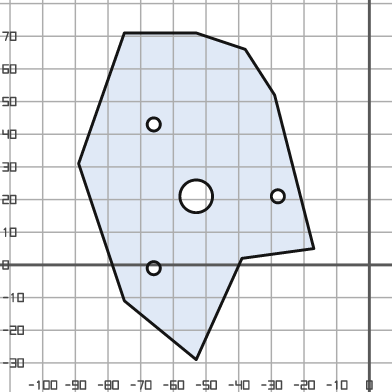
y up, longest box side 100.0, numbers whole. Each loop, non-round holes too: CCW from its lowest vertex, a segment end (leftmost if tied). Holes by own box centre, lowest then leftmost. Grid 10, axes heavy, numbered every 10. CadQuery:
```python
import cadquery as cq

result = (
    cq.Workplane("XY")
    .moveTo(-53.0, -29.0)
    .lineTo(-39.0, 2.0)
    .lineTo(-17.0, 5.0)
    .lineTo(-29.0, 52.0)
    .lineTo(-38.0, 66.0)
    .lineTo(-53.0, 71.0)
    .lineTo(-75.0, 71.0)
    .lineTo(-89.0, 31.0)
    .lineTo(-75.0, -11.0)
    .close()
    .moveTo(-66.0, -1.0)
    .circle(2.0)
    .moveTo(-53.0, 21.0)
    .circle(5.0)
    .moveTo(-28.0, 21.0)
    .circle(2.0)
    .moveTo(-66.0, 43.0)
    .circle(2.0)
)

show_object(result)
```